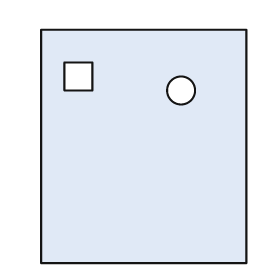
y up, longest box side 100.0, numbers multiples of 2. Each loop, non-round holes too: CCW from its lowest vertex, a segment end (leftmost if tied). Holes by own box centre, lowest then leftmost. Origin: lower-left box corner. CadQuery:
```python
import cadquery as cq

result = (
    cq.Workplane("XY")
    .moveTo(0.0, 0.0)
    .lineTo(88.0, 0.0)
    .lineTo(88.0, 100.0)
    .lineTo(0.0, 100.0)
    .close()
    .moveTo(60.0, 74.0)
    .circle(6.0)
    .moveTo(10.0, 74.0)
    .lineTo(22.0, 74.0)
    .lineTo(22.0, 86.0)
    .lineTo(10.0, 86.0)
    .close()
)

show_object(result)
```